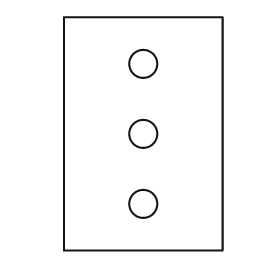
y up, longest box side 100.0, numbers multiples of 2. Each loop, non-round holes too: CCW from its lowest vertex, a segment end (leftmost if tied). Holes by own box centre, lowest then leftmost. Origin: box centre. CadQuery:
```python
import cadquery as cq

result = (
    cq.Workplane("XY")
    .moveTo(-34.0, -50.0)
    .lineTo(34.0, -50.0)
    .lineTo(34.0, 50.0)
    .lineTo(-34.0, 50.0)
    .close()
    .moveTo(0.0, -30.0)
    .circle(6.0)
    .moveTo(0.0, 0.0)
    .circle(6.0)
    .moveTo(0.0, 30.0)
    .circle(6.0)
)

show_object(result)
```